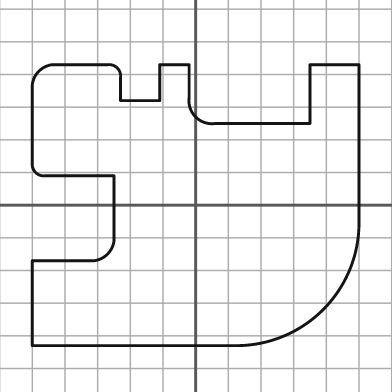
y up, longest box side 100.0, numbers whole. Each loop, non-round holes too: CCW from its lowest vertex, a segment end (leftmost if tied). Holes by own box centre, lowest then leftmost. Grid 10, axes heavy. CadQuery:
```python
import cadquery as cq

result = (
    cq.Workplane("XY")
    .moveTo(-50.0, -43.0)
    .lineTo(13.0, -43.0)
    .threePointArc((39.0, -32.0), (50.0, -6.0))
    .lineTo(50.0, 43.0)
    .lineTo(35.0, 43.0)
    .lineTo(35.0, 25.0)
    .lineTo(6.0, 25.0)
    .threePointArc((0.0, 27.0), (-2.0, 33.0))
    .lineTo(-2.0, 43.0)
    .lineTo(-11.0, 43.0)
    .lineTo(-11.0, 32.0)
    .lineTo(-23.0, 32.0)
    .lineTo(-23.0, 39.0)
    .threePointArc((-24.0, 42.0), (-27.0, 43.0))
    .lineTo(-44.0, 43.0)
    .threePointArc((-48.0, 41.0), (-50.0, 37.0))
    .lineTo(-50.0, 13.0)
    .threePointArc((-49.0, 10.0), (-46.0, 9.0))
    .lineTo(-25.0, 9.0)
    .lineTo(-25.0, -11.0)
    .threePointArc((-27.0, -15.0), (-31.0, -17.0))
    .lineTo(-50.0, -17.0)
    .close()
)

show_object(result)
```